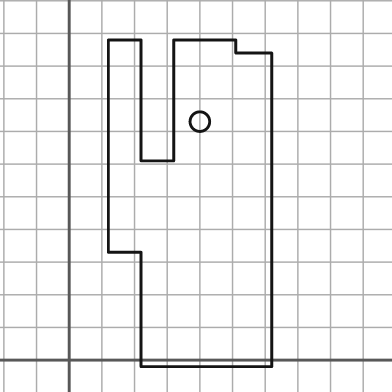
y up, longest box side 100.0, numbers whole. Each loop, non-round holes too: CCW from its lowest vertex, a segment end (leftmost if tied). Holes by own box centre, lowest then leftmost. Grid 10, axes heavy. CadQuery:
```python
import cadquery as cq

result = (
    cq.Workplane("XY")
    .moveTo(22.0, -2.0)
    .lineTo(62.0, -2.0)
    .lineTo(62.0, 94.0)
    .lineTo(51.0, 94.0)
    .lineTo(51.0, 98.0)
    .lineTo(32.0, 98.0)
    .lineTo(32.0, 61.0)
    .lineTo(22.0, 61.0)
    .lineTo(22.0, 98.0)
    .lineTo(12.0, 98.0)
    .lineTo(12.0, 33.0)
    .lineTo(22.0, 33.0)
    .close()
    .moveTo(40.0, 73.0)
    .circle(3.0)
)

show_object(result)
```